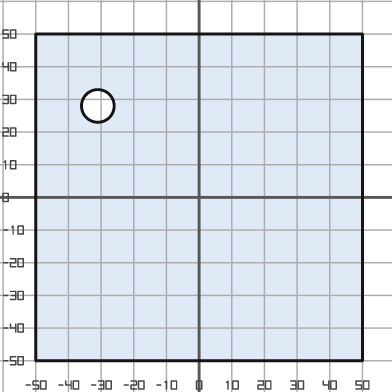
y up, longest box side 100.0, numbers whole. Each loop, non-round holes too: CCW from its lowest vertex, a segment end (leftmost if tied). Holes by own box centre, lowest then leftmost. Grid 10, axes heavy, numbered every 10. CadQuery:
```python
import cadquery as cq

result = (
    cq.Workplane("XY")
    .moveTo(-50.0, -50.0)
    .lineTo(50.0, -50.0)
    .lineTo(50.0, 50.0)
    .lineTo(-50.0, 50.0)
    .close()
    .moveTo(-31.0, 28.0)
    .circle(5.0)
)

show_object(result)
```